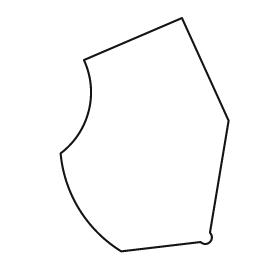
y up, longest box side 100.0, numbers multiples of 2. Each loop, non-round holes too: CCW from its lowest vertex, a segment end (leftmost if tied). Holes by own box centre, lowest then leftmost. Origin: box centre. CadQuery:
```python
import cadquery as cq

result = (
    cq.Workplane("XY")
    .moveTo(-10.0, -50.0)
    .lineTo(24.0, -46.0)
    .threePointArc((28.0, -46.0), (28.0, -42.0))
    .lineTo(36.0, 6.0)
    .lineTo(16.0, 50.0)
    .lineTo(-26.0, 32.0)
    .threePointArc((-24.0, 10.0), (-36.0, -8.0))
    .threePointArc((-28.0, -32.0), (-10.0, -50.0))
    .close()
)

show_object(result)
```